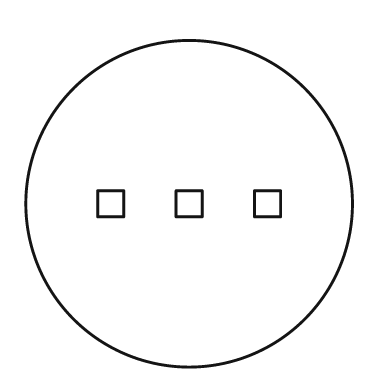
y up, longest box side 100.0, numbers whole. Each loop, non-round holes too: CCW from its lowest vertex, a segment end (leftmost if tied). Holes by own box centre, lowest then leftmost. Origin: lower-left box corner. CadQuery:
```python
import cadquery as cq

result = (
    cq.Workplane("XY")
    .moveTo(50.0, 50.0)
    .circle(50.0)
    .moveTo(22.0, 46.0)
    .lineTo(30.0, 46.0)
    .lineTo(30.0, 54.0)
    .lineTo(22.0, 54.0)
    .close()
    .moveTo(46.0, 46.0)
    .lineTo(54.0, 46.0)
    .lineTo(54.0, 54.0)
    .lineTo(46.0, 54.0)
    .close()
    .moveTo(70.0, 46.0)
    .lineTo(78.0, 46.0)
    .lineTo(78.0, 54.0)
    .lineTo(70.0, 54.0)
    .close()
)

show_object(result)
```